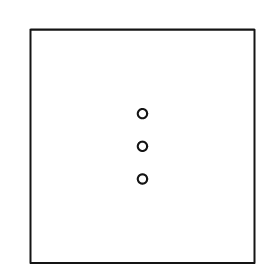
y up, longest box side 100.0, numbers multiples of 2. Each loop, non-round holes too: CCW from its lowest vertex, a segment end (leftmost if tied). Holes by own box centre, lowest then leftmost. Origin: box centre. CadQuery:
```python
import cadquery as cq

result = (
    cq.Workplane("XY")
    .moveTo(-48.0, -50.0)
    .lineTo(48.0, -50.0)
    .lineTo(48.0, 50.0)
    .lineTo(-48.0, 50.0)
    .close()
    .moveTo(0.0, -14.0)
    .circle(2.0)
    .moveTo(0.0, 0.0)
    .circle(2.0)
    .moveTo(0.0, 14.0)
    .circle(2.0)
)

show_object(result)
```